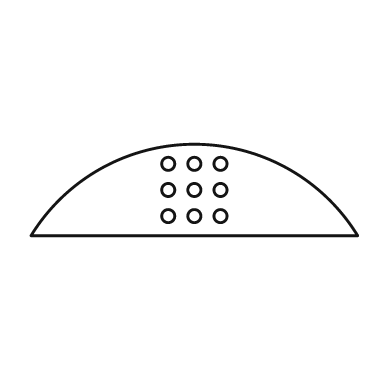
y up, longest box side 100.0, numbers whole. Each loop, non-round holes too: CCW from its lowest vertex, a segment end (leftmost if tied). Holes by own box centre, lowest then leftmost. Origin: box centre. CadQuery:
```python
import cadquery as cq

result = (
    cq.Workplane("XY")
    .moveTo(-50.0, -14.0)
    .lineTo(50.0, -14.0)
    .threePointArc((0.0, 14.0), (-50.0, -14.0))
    .close()
    .moveTo(-8.0, -8.0)
    .circle(2.0)
    .moveTo(0.0, -8.0)
    .circle(2.0)
    .moveTo(8.0, -8.0)
    .circle(2.0)
    .moveTo(-8.0, 0.0)
    .circle(2.0)
    .moveTo(0.0, 0.0)
    .circle(2.0)
    .moveTo(8.0, 0.0)
    .circle(2.0)
    .moveTo(-8.0, 8.0)
    .circle(2.0)
    .moveTo(0.0, 8.0)
    .circle(2.0)
    .moveTo(8.0, 8.0)
    .circle(2.0)
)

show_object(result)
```